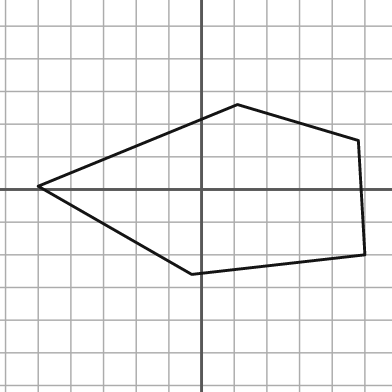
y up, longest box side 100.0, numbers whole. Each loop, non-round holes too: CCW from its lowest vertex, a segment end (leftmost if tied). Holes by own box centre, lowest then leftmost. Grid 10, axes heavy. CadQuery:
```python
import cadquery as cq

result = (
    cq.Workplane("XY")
    .moveTo(-3.0, -26.0)
    .lineTo(50.0, -20.0)
    .lineTo(48.0, 15.0)
    .lineTo(11.0, 26.0)
    .lineTo(-50.0, 1.0)
    .close()
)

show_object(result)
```